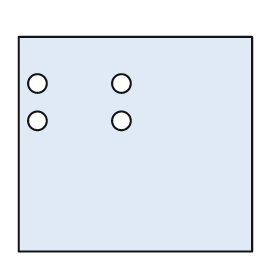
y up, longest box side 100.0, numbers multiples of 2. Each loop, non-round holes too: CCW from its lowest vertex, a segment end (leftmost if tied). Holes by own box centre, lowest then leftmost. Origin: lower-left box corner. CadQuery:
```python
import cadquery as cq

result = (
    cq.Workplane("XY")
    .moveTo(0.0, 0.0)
    .lineTo(100.0, 0.0)
    .lineTo(100.0, 92.0)
    .lineTo(0.0, 92.0)
    .close()
    .moveTo(8.0, 56.0)
    .circle(4.0)
    .moveTo(44.0, 56.0)
    .circle(4.0)
    .moveTo(8.0, 72.0)
    .circle(4.0)
    .moveTo(44.0, 72.0)
    .circle(4.0)
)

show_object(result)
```